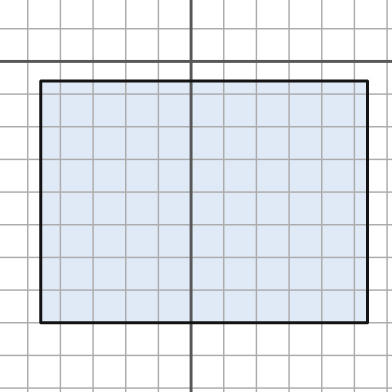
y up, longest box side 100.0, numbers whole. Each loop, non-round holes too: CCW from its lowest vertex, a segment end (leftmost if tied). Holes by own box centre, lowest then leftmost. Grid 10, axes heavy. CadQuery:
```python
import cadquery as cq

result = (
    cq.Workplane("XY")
    .moveTo(-46.0, -80.0)
    .lineTo(54.0, -80.0)
    .lineTo(54.0, -6.0)
    .lineTo(-46.0, -6.0)
    .close()
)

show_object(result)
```